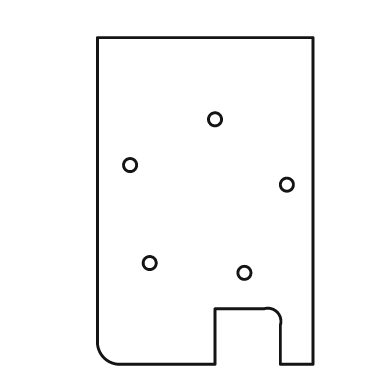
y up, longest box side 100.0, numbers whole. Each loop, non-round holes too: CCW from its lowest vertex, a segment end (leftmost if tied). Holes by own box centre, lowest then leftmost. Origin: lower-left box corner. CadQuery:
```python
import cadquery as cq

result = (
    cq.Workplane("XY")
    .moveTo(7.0, 0.0)
    .lineTo(36.0, 0.0)
    .lineTo(36.0, 17.0)
    .lineTo(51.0, 17.0)
    .threePointArc((55.0, 16.0), (56.0, 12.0))
    .lineTo(56.0, 0.0)
    .lineTo(66.0, 0.0)
    .lineTo(66.0, 100.0)
    .lineTo(0.0, 100.0)
    .lineTo(0.0, 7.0)
    .threePointArc((2.0, 2.0), (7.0, 0.0))
    .close()
    .moveTo(45.0, 28.0)
    .circle(2.0)
    .moveTo(16.0, 31.0)
    .circle(2.0)
    .moveTo(58.0, 55.0)
    .circle(2.0)
    .moveTo(10.0, 61.0)
    .circle(2.0)
    .moveTo(36.0, 75.0)
    .circle(2.0)
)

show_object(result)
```